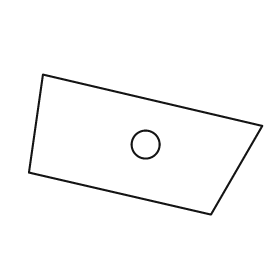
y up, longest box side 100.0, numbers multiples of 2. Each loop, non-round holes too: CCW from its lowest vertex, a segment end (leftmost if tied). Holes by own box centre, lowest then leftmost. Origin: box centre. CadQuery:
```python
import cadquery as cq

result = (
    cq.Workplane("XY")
    .moveTo(28.0, -30.0)
    .lineTo(50.0, 8.0)
    .lineTo(-44.0, 30.0)
    .lineTo(-50.0, -12.0)
    .close()
    .moveTo(0.0, 0.0)
    .circle(6.0)
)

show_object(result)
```